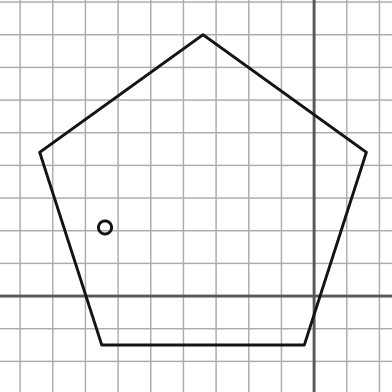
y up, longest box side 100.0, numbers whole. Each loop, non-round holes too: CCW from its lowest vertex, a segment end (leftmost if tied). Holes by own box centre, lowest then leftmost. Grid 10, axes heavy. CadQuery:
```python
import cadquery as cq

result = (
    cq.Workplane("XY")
    .moveTo(-65.0, -15.0)
    .lineTo(-3.0, -15.0)
    .lineTo(16.0, 44.0)
    .lineTo(-34.0, 80.0)
    .lineTo(-84.0, 44.0)
    .close()
    .moveTo(-64.0, 21.0)
    .circle(2.0)
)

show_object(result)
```